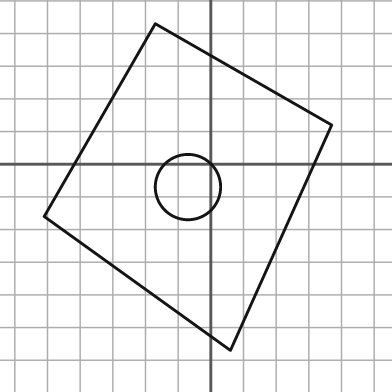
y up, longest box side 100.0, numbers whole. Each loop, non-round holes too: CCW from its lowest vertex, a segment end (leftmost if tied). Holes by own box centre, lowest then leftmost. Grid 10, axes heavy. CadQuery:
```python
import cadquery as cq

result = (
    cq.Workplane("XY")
    .moveTo(6.0, -57.0)
    .lineTo(37.0, 12.0)
    .lineTo(-17.0, 43.0)
    .lineTo(-51.0, -16.0)
    .close()
    .moveTo(-7.0, -7.0)
    .circle(10.0)
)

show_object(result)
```